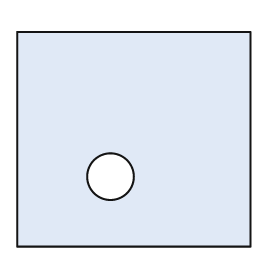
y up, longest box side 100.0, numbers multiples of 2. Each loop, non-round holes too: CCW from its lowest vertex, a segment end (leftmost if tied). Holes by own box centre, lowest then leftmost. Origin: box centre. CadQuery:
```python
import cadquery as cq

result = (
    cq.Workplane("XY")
    .moveTo(-50.0, -46.0)
    .lineTo(50.0, -46.0)
    .lineTo(50.0, 46.0)
    .lineTo(-50.0, 46.0)
    .close()
    .moveTo(-10.0, -16.0)
    .circle(10.0)
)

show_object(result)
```